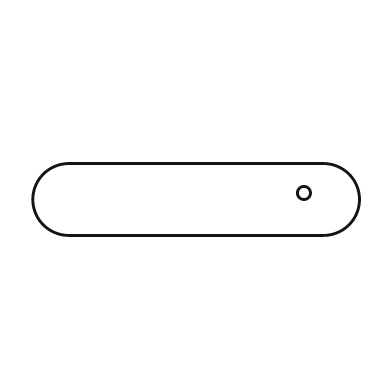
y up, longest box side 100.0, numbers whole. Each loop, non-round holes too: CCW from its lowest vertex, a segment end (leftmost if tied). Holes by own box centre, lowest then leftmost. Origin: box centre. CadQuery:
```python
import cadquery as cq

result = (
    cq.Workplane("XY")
    .moveTo(-39.0, -11.0)
    .lineTo(39.0, -11.0)
    .threePointArc((50.0, 0.0), (39.0, 11.0))
    .lineTo(-39.0, 11.0)
    .threePointArc((-50.0, 0.0), (-39.0, -11.0))
    .close()
    .moveTo(33.0, 2.0)
    .circle(2.0)
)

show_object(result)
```